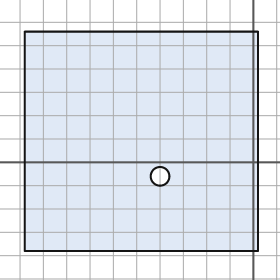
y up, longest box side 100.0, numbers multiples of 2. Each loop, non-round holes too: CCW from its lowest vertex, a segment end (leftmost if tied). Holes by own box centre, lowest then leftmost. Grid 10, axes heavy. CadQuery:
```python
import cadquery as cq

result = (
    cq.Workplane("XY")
    .moveTo(-98.0, -38.0)
    .lineTo(2.0, -38.0)
    .lineTo(2.0, 56.0)
    .lineTo(-98.0, 56.0)
    .close()
    .moveTo(-40.0, -6.0)
    .circle(4.0)
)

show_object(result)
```